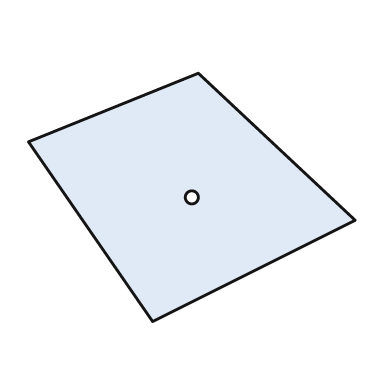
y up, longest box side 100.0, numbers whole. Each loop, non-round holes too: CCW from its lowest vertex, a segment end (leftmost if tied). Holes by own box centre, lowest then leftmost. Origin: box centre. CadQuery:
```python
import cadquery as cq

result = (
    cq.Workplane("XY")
    .moveTo(-12.0, -38.0)
    .lineTo(50.0, -7.0)
    .lineTo(2.0, 38.0)
    .lineTo(-50.0, 17.0)
    .close()
    .moveTo(0.0, 0.0)
    .circle(2.0)
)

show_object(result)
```